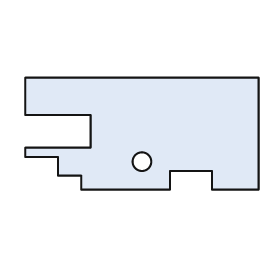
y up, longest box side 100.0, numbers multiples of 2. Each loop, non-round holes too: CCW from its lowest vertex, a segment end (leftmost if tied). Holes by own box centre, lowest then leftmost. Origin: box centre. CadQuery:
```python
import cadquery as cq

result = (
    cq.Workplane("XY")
    .moveTo(-26.0, -24.0)
    .lineTo(12.0, -24.0)
    .lineTo(12.0, -16.0)
    .lineTo(30.0, -16.0)
    .lineTo(30.0, -24.0)
    .lineTo(50.0, -24.0)
    .lineTo(50.0, 24.0)
    .lineTo(-50.0, 24.0)
    .lineTo(-50.0, 8.0)
    .lineTo(-22.0, 8.0)
    .lineTo(-22.0, -6.0)
    .lineTo(-50.0, -6.0)
    .lineTo(-50.0, -10.0)
    .lineTo(-36.0, -10.0)
    .lineTo(-36.0, -18.0)
    .lineTo(-26.0, -18.0)
    .close()
    .moveTo(0.0, -12.0)
    .circle(4.0)
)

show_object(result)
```